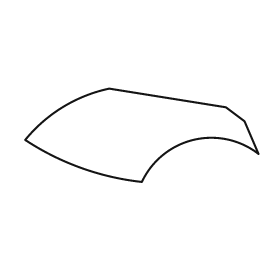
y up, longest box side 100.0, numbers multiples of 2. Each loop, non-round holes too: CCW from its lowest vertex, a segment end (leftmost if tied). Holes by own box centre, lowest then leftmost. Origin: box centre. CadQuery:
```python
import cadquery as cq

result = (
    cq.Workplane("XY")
    .moveTo(0.0, -20.0)
    .threePointArc((22.0, -2.0), (50.0, -8.0))
    .lineTo(44.0, 6.0)
    .lineTo(36.0, 12.0)
    .lineTo(-14.0, 20.0)
    .threePointArc((-34.0, 12.0), (-50.0, -2.0))
    .threePointArc((-26.0, -14.0), (0.0, -20.0))
    .close()
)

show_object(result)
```